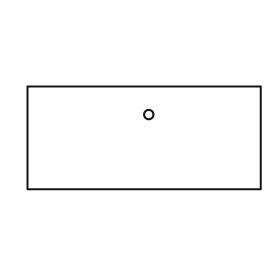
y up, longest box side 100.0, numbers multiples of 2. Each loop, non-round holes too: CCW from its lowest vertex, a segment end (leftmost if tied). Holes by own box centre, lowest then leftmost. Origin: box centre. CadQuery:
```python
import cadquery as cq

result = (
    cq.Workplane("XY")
    .moveTo(-50.0, -22.0)
    .lineTo(50.0, -22.0)
    .lineTo(50.0, 22.0)
    .lineTo(-50.0, 22.0)
    .close()
    .moveTo(2.0, 10.0)
    .circle(2.0)
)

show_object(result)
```